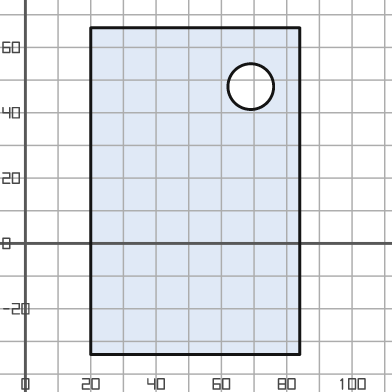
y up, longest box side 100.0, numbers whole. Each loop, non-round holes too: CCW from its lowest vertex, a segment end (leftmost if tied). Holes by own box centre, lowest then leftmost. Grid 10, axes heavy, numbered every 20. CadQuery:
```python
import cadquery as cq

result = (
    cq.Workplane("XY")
    .moveTo(20.0, -34.0)
    .lineTo(84.0, -34.0)
    .lineTo(84.0, 66.0)
    .lineTo(20.0, 66.0)
    .close()
    .moveTo(69.0, 48.0)
    .circle(7.0)
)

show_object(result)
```